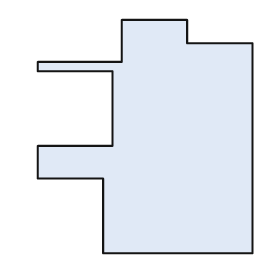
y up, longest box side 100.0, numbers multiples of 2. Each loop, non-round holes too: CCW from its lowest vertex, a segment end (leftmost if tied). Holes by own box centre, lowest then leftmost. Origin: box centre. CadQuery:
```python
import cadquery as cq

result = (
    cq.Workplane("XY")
    .moveTo(-18.0, -50.0)
    .lineTo(46.0, -50.0)
    .lineTo(46.0, 40.0)
    .lineTo(18.0, 40.0)
    .lineTo(18.0, 50.0)
    .lineTo(-10.0, 50.0)
    .lineTo(-10.0, 32.0)
    .lineTo(-46.0, 32.0)
    .lineTo(-46.0, 28.0)
    .lineTo(-14.0, 28.0)
    .lineTo(-14.0, -4.0)
    .lineTo(-46.0, -4.0)
    .lineTo(-46.0, -18.0)
    .lineTo(-18.0, -18.0)
    .close()
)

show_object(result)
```